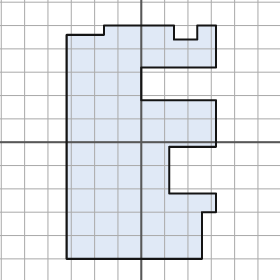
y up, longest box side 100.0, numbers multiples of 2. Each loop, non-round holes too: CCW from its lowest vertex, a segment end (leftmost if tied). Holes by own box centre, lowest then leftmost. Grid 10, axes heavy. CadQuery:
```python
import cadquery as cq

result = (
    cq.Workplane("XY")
    .moveTo(-32.0, -50.0)
    .lineTo(26.0, -50.0)
    .lineTo(26.0, -30.0)
    .lineTo(32.0, -30.0)
    .lineTo(32.0, -22.0)
    .lineTo(12.0, -22.0)
    .lineTo(12.0, -2.0)
    .lineTo(32.0, -2.0)
    .lineTo(32.0, 18.0)
    .lineTo(0.0, 18.0)
    .lineTo(0.0, 32.0)
    .lineTo(32.0, 32.0)
    .lineTo(32.0, 50.0)
    .lineTo(24.0, 50.0)
    .lineTo(24.0, 44.0)
    .lineTo(14.0, 44.0)
    .lineTo(14.0, 50.0)
    .lineTo(-16.0, 50.0)
    .lineTo(-16.0, 46.0)
    .lineTo(-32.0, 46.0)
    .close()
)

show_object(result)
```